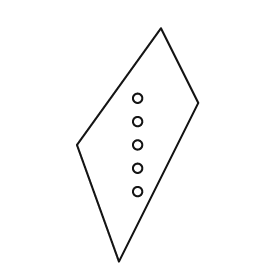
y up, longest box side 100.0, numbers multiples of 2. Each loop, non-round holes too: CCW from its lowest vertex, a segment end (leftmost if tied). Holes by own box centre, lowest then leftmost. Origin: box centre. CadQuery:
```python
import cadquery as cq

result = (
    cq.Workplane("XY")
    .moveTo(-8.0, -50.0)
    .lineTo(26.0, 18.0)
    .lineTo(10.0, 50.0)
    .lineTo(-26.0, 0.0)
    .close()
    .moveTo(0.0, -20.0)
    .circle(2.0)
    .moveTo(0.0, -10.0)
    .circle(2.0)
    .moveTo(0.0, 0.0)
    .circle(2.0)
    .moveTo(0.0, 10.0)
    .circle(2.0)
    .moveTo(0.0, 20.0)
    .circle(2.0)
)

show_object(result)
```